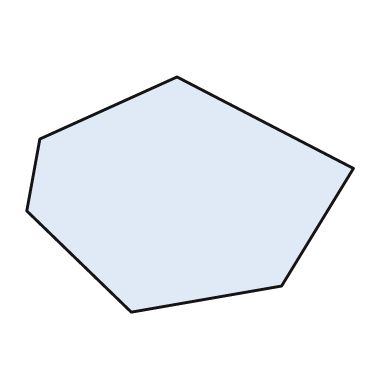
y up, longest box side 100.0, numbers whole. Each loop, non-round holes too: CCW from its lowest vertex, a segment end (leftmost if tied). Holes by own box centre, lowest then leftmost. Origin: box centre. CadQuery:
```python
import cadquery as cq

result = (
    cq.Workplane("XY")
    .moveTo(-18.0, -36.0)
    .lineTo(28.0, -28.0)
    .lineTo(50.0, 8.0)
    .lineTo(-4.0, 36.0)
    .lineTo(-46.0, 17.0)
    .lineTo(-50.0, -5.0)
    .close()
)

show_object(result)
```